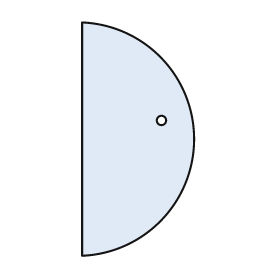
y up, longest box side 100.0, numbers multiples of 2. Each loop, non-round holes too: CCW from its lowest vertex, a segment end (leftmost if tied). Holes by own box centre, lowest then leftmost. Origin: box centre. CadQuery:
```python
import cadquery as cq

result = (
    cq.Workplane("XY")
    .moveTo(-24.0, -50.0)
    .threePointArc((24.0, 0.0), (-24.0, 50.0))
    .close()
    .moveTo(10.0, 8.0)
    .circle(2.0)
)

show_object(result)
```